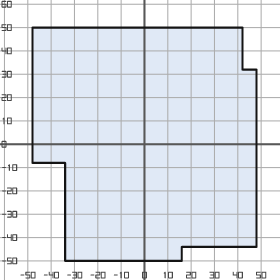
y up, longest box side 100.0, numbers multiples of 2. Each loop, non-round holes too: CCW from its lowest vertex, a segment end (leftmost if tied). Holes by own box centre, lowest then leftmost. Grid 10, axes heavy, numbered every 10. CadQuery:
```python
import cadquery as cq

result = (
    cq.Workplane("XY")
    .moveTo(-34.0, -50.0)
    .lineTo(16.0, -50.0)
    .lineTo(16.0, -44.0)
    .lineTo(48.0, -44.0)
    .lineTo(48.0, 32.0)
    .lineTo(42.0, 32.0)
    .lineTo(42.0, 50.0)
    .lineTo(-48.0, 50.0)
    .lineTo(-48.0, -8.0)
    .lineTo(-34.0, -8.0)
    .close()
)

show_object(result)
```